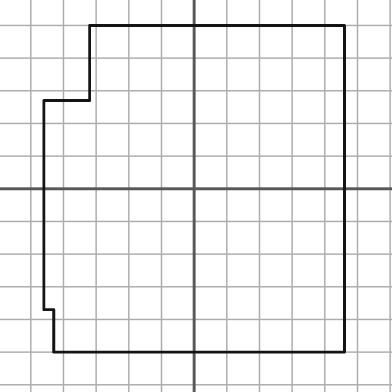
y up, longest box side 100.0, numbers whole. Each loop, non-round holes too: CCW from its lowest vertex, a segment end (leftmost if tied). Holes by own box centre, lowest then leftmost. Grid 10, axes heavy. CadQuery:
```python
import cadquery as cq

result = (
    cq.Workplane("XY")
    .moveTo(-43.0, -50.0)
    .lineTo(46.0, -50.0)
    .lineTo(46.0, 50.0)
    .lineTo(-32.0, 50.0)
    .lineTo(-32.0, 27.0)
    .lineTo(-46.0, 27.0)
    .lineTo(-46.0, -37.0)
    .lineTo(-43.0, -37.0)
    .close()
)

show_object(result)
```